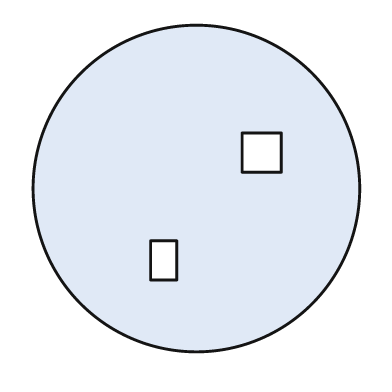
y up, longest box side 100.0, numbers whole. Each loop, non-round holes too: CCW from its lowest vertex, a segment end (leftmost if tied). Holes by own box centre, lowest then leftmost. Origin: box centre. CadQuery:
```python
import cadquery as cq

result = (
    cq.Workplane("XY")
    .moveTo(0.0, 0.0)
    .circle(50.0)
    .moveTo(-14.0, -28.0)
    .lineTo(-6.0, -28.0)
    .lineTo(-6.0, -16.0)
    .lineTo(-14.0, -16.0)
    .close()
    .moveTo(14.0, 5.0)
    .lineTo(26.0, 5.0)
    .lineTo(26.0, 17.0)
    .lineTo(14.0, 17.0)
    .close()
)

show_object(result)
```